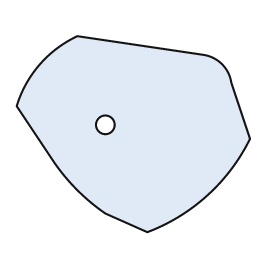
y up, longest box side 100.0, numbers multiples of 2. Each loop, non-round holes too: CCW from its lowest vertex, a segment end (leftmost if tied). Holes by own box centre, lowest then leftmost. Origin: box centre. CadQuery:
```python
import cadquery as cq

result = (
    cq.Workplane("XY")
    .moveTo(6.0, -42.0)
    .threePointArc((32.0, -26.0), (50.0, -2.0))
    .lineTo(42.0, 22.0)
    .threePointArc((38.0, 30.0), (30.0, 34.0))
    .lineTo(-24.0, 42.0)
    .threePointArc((-40.0, 30.0), (-50.0, 12.0))
    .lineTo(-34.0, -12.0)
    .threePointArc((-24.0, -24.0), (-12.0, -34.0))
    .close()
    .moveTo(-12.0, 4.0)
    .circle(4.0)
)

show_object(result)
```